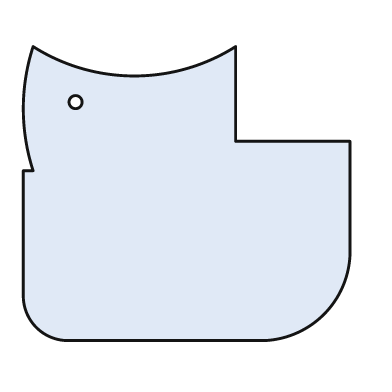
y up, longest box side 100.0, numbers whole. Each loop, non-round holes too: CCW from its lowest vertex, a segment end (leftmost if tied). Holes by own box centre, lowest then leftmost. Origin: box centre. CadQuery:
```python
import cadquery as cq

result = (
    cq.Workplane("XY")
    .moveTo(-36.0, -45.0)
    .lineTo(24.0, -45.0)
    .threePointArc((42.0, -37.0), (50.0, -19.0))
    .lineTo(50.0, 16.0)
    .lineTo(15.0, 16.0)
    .lineTo(15.0, 45.0)
    .threePointArc((-16.0, 36.0), (-47.0, 45.0))
    .threePointArc((-50.0, 26.0), (-47.0, 7.0))
    .lineTo(-50.0, 7.0)
    .lineTo(-50.0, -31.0)
    .threePointArc((-46.0, -41.0), (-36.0, -45.0))
    .close()
    .moveTo(-34.0, 28.0)
    .circle(2.0)
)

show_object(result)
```